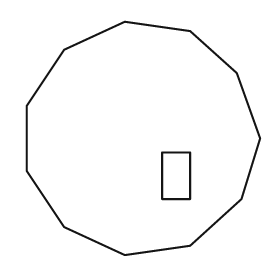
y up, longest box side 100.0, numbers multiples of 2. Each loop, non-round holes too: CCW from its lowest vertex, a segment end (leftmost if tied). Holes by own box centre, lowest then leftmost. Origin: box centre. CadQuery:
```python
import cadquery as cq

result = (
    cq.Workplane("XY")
    .moveTo(-8.0, -50.0)
    .lineTo(20.0, -46.0)
    .lineTo(42.0, -26.0)
    .lineTo(50.0, 0.0)
    .lineTo(40.0, 28.0)
    .lineTo(20.0, 46.0)
    .lineTo(-8.0, 50.0)
    .lineTo(-34.0, 38.0)
    .lineTo(-50.0, 14.0)
    .lineTo(-50.0, -14.0)
    .lineTo(-34.0, -38.0)
    .close()
    .moveTo(8.0, -26.0)
    .lineTo(20.0, -26.0)
    .lineTo(20.0, -6.0)
    .lineTo(8.0, -6.0)
    .close()
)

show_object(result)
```